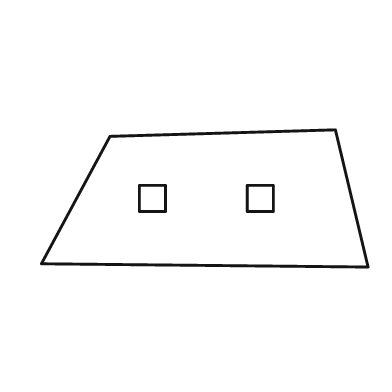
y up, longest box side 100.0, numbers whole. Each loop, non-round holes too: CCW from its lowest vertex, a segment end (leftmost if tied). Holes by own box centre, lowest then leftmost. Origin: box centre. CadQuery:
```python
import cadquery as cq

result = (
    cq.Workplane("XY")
    .moveTo(50.0, -21.0)
    .lineTo(40.0, 21.0)
    .lineTo(-29.0, 19.0)
    .lineTo(-50.0, -20.0)
    .close()
    .moveTo(-20.0, -4.0)
    .lineTo(-12.0, -4.0)
    .lineTo(-12.0, 4.0)
    .lineTo(-20.0, 4.0)
    .close()
    .moveTo(13.0, -4.0)
    .lineTo(21.0, -4.0)
    .lineTo(21.0, 4.0)
    .lineTo(13.0, 4.0)
    .close()
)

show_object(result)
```